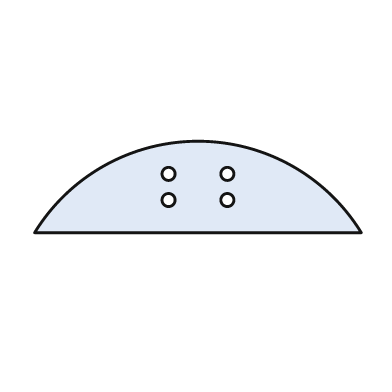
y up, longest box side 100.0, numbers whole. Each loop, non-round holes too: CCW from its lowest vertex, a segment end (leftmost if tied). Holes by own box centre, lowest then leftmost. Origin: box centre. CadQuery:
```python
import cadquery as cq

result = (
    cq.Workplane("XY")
    .moveTo(-50.0, -14.0)
    .lineTo(50.0, -14.0)
    .threePointArc((0.0, 14.0), (-50.0, -14.0))
    .close()
    .moveTo(-9.0, -4.0)
    .circle(2.0)
    .moveTo(9.0, -4.0)
    .circle(2.0)
    .moveTo(-9.0, 4.0)
    .circle(2.0)
    .moveTo(9.0, 4.0)
    .circle(2.0)
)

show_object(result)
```